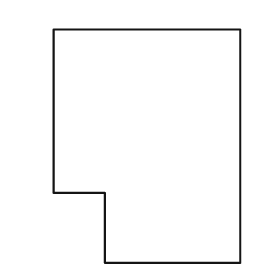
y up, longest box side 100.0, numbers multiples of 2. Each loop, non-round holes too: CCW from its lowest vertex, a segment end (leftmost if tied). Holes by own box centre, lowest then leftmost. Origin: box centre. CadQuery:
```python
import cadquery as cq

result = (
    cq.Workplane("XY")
    .moveTo(-18.0, -50.0)
    .lineTo(40.0, -50.0)
    .lineTo(40.0, 50.0)
    .lineTo(-40.0, 50.0)
    .lineTo(-40.0, -20.0)
    .lineTo(-18.0, -20.0)
    .close()
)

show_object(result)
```